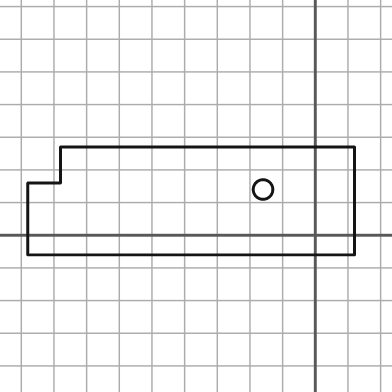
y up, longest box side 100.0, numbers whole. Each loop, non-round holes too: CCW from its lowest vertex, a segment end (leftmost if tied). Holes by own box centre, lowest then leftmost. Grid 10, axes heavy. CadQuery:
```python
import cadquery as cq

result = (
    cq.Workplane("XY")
    .moveTo(-88.0, -6.0)
    .lineTo(12.0, -6.0)
    .lineTo(12.0, 27.0)
    .lineTo(-78.0, 27.0)
    .lineTo(-78.0, 16.0)
    .lineTo(-88.0, 16.0)
    .close()
    .moveTo(-16.0, 14.0)
    .circle(3.0)
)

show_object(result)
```